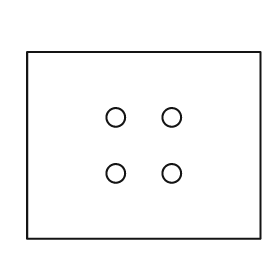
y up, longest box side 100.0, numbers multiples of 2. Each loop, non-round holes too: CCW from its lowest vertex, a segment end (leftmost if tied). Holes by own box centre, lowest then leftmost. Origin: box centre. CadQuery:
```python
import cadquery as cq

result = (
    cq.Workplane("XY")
    .moveTo(-50.0, -40.0)
    .lineTo(50.0, -40.0)
    .lineTo(50.0, 40.0)
    .lineTo(-50.0, 40.0)
    .close()
    .moveTo(-12.0, -12.0)
    .circle(4.0)
    .moveTo(12.0, -12.0)
    .circle(4.0)
    .moveTo(-12.0, 12.0)
    .circle(4.0)
    .moveTo(12.0, 12.0)
    .circle(4.0)
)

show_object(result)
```